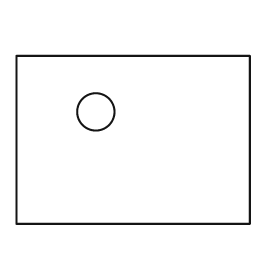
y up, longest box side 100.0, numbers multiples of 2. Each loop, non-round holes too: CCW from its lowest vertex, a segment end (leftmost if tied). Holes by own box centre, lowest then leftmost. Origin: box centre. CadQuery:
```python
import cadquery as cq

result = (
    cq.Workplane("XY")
    .moveTo(-50.0, -36.0)
    .lineTo(50.0, -36.0)
    .lineTo(50.0, 36.0)
    .lineTo(-50.0, 36.0)
    .close()
    .moveTo(-16.0, 12.0)
    .circle(8.0)
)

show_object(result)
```